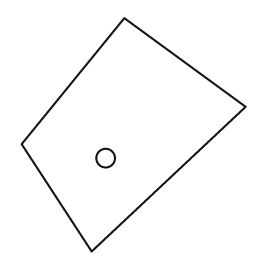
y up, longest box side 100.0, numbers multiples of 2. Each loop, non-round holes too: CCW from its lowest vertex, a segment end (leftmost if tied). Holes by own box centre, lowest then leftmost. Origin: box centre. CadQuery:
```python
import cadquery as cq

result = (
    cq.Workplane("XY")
    .moveTo(-18.0, -50.0)
    .lineTo(48.0, 12.0)
    .lineTo(-4.0, 50.0)
    .lineTo(-48.0, -4.0)
    .close()
    .moveTo(-12.0, -10.0)
    .circle(4.0)
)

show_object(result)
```